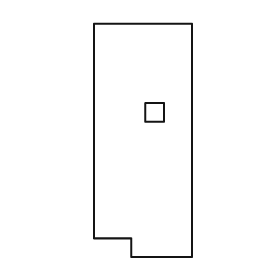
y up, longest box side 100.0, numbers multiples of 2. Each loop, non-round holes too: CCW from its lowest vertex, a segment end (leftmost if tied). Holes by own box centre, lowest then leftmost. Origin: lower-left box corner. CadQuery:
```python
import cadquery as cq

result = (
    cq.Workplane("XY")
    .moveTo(16.0, 0.0)
    .lineTo(42.0, 0.0)
    .lineTo(42.0, 100.0)
    .lineTo(0.0, 100.0)
    .lineTo(0.0, 8.0)
    .lineTo(16.0, 8.0)
    .close()
    .moveTo(22.0, 58.0)
    .lineTo(30.0, 58.0)
    .lineTo(30.0, 66.0)
    .lineTo(22.0, 66.0)
    .close()
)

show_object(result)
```